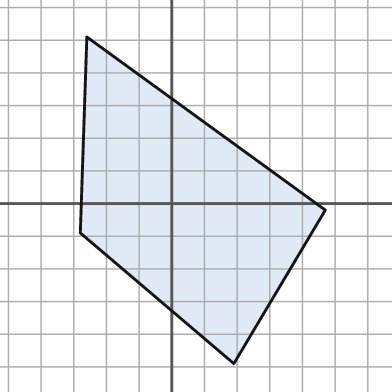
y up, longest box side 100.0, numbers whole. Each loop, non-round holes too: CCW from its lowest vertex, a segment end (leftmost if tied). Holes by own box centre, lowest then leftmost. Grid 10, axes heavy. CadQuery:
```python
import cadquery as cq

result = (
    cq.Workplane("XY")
    .moveTo(19.0, -49.0)
    .lineTo(47.0, -2.0)
    .lineTo(-26.0, 51.0)
    .lineTo(-28.0, -9.0)
    .close()
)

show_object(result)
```